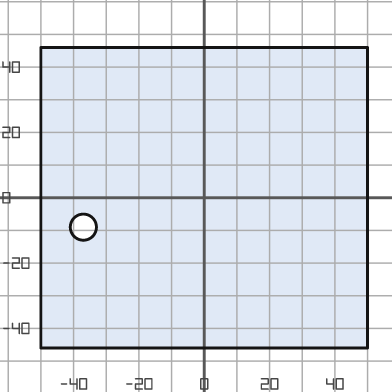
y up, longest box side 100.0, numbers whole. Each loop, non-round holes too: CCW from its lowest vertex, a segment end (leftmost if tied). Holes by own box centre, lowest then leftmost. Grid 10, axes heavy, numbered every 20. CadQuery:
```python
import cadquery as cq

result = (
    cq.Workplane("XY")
    .moveTo(-50.0, -46.0)
    .lineTo(50.0, -46.0)
    .lineTo(50.0, 46.0)
    .lineTo(-50.0, 46.0)
    .close()
    .moveTo(-37.0, -9.0)
    .circle(4.0)
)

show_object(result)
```